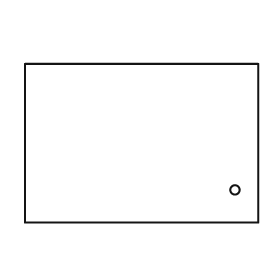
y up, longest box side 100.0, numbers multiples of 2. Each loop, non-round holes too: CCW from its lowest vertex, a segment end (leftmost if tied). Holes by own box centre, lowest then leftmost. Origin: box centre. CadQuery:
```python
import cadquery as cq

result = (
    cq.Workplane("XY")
    .moveTo(-50.0, -34.0)
    .lineTo(50.0, -34.0)
    .lineTo(50.0, 34.0)
    .lineTo(-50.0, 34.0)
    .close()
    .moveTo(40.0, -20.0)
    .circle(2.0)
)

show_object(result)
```